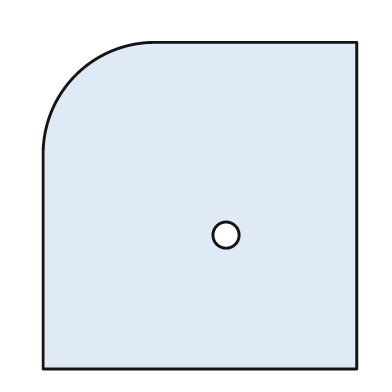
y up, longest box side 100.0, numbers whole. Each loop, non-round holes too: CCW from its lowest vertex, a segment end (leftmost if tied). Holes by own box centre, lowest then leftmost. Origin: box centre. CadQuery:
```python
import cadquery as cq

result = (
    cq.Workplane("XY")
    .moveTo(-48.0, -50.0)
    .lineTo(48.0, -50.0)
    .lineTo(48.0, 50.0)
    .lineTo(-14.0, 50.0)
    .threePointArc((-38.0, 40.0), (-48.0, 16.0))
    .close()
    .moveTo(8.0, -9.0)
    .circle(4.0)
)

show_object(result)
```